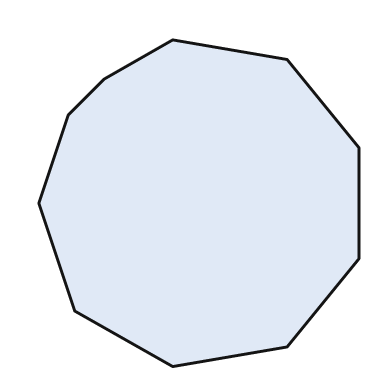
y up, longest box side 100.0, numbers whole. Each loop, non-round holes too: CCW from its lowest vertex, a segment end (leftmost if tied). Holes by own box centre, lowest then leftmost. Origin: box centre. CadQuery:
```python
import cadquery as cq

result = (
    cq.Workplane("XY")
    .moveTo(-8.0, -50.0)
    .lineTo(27.0, -44.0)
    .lineTo(49.0, -17.0)
    .lineTo(49.0, 17.0)
    .lineTo(27.0, 44.0)
    .lineTo(-8.0, 50.0)
    .lineTo(-29.0, 38.0)
    .lineTo(-40.0, 27.0)
    .lineTo(-49.0, 0.0)
    .lineTo(-38.0, -33.0)
    .close()
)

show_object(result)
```